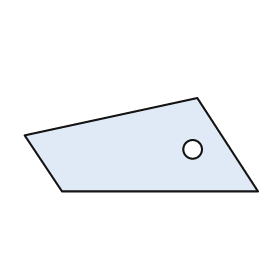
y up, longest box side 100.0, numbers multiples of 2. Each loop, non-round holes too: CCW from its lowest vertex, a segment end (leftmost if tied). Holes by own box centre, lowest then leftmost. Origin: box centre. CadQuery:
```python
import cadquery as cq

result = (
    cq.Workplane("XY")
    .moveTo(-34.0, -20.0)
    .lineTo(50.0, -20.0)
    .lineTo(24.0, 20.0)
    .lineTo(-50.0, 4.0)
    .close()
    .moveTo(22.0, -2.0)
    .circle(4.0)
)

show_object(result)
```